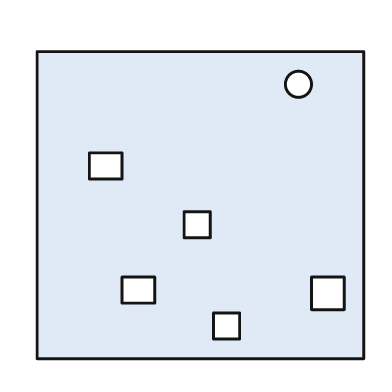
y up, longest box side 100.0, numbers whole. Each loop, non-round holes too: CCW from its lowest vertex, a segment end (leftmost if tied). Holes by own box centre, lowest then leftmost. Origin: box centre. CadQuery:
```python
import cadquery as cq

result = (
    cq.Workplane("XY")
    .moveTo(-50.0, -47.0)
    .lineTo(50.0, -47.0)
    .lineTo(50.0, 47.0)
    .lineTo(-50.0, 47.0)
    .close()
    .moveTo(4.0, -41.0)
    .lineTo(12.0, -41.0)
    .lineTo(12.0, -33.0)
    .lineTo(4.0, -33.0)
    .close()
    .moveTo(34.0, -32.0)
    .lineTo(44.0, -32.0)
    .lineTo(44.0, -22.0)
    .lineTo(34.0, -22.0)
    .close()
    .moveTo(-24.0, -30.0)
    .lineTo(-14.0, -30.0)
    .lineTo(-14.0, -22.0)
    .lineTo(-24.0, -22.0)
    .close()
    .moveTo(-5.0, -10.0)
    .lineTo(3.0, -10.0)
    .lineTo(3.0, -2.0)
    .lineTo(-5.0, -2.0)
    .close()
    .moveTo(-34.0, 8.0)
    .lineTo(-24.0, 8.0)
    .lineTo(-24.0, 16.0)
    .lineTo(-34.0, 16.0)
    .close()
    .moveTo(30.0, 37.0)
    .circle(4.0)
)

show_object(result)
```